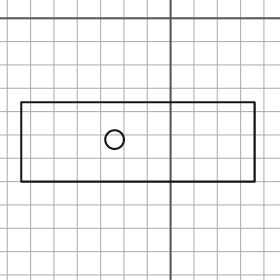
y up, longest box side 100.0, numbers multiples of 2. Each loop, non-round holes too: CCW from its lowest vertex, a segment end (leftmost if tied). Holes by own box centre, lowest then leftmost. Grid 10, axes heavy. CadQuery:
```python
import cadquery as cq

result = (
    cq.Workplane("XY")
    .moveTo(-64.0, -70.0)
    .lineTo(36.0, -70.0)
    .lineTo(36.0, -36.0)
    .lineTo(-64.0, -36.0)
    .close()
    .moveTo(-24.0, -52.0)
    .circle(4.0)
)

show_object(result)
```